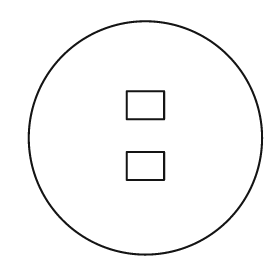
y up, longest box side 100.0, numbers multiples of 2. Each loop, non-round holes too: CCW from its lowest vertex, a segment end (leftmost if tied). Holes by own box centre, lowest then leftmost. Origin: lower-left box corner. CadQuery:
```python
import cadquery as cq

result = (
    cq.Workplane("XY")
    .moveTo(50.0, 50.0)
    .circle(50.0)
    .moveTo(42.0, 32.0)
    .lineTo(58.0, 32.0)
    .lineTo(58.0, 44.0)
    .lineTo(42.0, 44.0)
    .close()
    .moveTo(42.0, 58.0)
    .lineTo(58.0, 58.0)
    .lineTo(58.0, 70.0)
    .lineTo(42.0, 70.0)
    .close()
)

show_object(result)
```